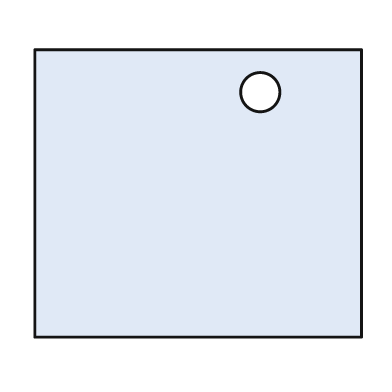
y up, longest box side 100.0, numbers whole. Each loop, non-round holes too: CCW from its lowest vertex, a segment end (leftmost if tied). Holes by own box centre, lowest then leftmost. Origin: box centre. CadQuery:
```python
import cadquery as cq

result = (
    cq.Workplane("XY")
    .moveTo(-50.0, -44.0)
    .lineTo(50.0, -44.0)
    .lineTo(50.0, 44.0)
    .lineTo(-50.0, 44.0)
    .close()
    .moveTo(19.0, 31.0)
    .circle(6.0)
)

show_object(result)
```